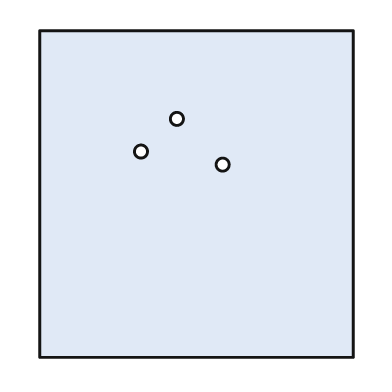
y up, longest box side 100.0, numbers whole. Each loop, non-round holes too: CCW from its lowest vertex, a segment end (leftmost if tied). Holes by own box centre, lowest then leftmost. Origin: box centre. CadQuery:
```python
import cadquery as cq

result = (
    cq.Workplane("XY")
    .moveTo(-48.0, -50.0)
    .lineTo(48.0, -50.0)
    .lineTo(48.0, 50.0)
    .lineTo(-48.0, 50.0)
    .close()
    .moveTo(8.0, 9.0)
    .circle(2.0)
    .moveTo(-17.0, 13.0)
    .circle(2.0)
    .moveTo(-6.0, 23.0)
    .circle(2.0)
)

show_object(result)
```